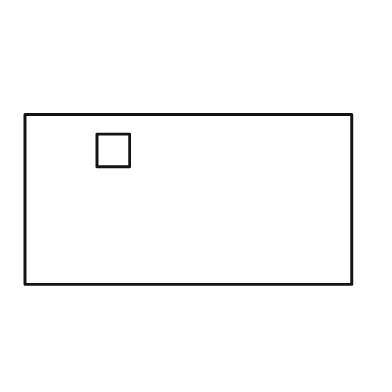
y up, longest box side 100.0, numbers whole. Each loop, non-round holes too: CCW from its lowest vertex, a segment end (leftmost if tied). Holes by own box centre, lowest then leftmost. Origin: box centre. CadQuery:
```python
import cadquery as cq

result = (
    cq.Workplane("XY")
    .moveTo(-50.0, -26.0)
    .lineTo(50.0, -26.0)
    .lineTo(50.0, 26.0)
    .lineTo(-50.0, 26.0)
    .close()
    .moveTo(-28.0, 10.0)
    .lineTo(-18.0, 10.0)
    .lineTo(-18.0, 20.0)
    .lineTo(-28.0, 20.0)
    .close()
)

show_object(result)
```